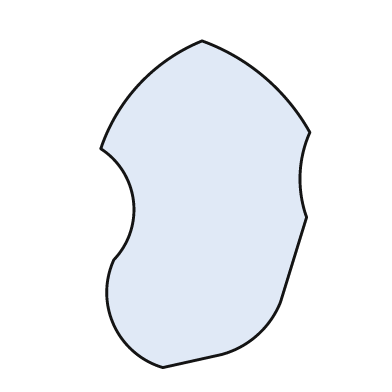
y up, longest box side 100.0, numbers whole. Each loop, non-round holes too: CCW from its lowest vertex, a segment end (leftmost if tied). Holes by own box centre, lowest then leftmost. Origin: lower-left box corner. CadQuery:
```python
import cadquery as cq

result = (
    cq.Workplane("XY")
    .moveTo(19.0, 0.0)
    .lineTo(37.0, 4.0)
    .threePointArc((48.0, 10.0), (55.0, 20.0))
    .lineTo(63.0, 46.0)
    .threePointArc((61.0, 59.0), (64.0, 72.0))
    .threePointArc((50.0, 89.0), (31.0, 100.0))
    .threePointArc((12.0, 87.0), (0.0, 67.0))
    .threePointArc((10.0, 51.0), (4.0, 33.0))
    .threePointArc((4.0, 13.0), (19.0, 0.0))
    .close()
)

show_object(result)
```